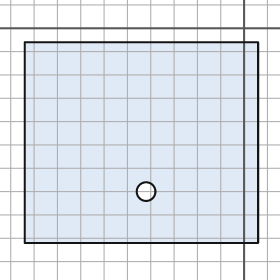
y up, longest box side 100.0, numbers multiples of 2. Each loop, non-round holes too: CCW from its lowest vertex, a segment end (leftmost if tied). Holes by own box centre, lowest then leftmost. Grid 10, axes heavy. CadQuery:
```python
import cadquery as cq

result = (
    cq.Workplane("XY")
    .moveTo(-94.0, -92.0)
    .lineTo(6.0, -92.0)
    .lineTo(6.0, -6.0)
    .lineTo(-94.0, -6.0)
    .close()
    .moveTo(-42.0, -70.0)
    .circle(4.0)
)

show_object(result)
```